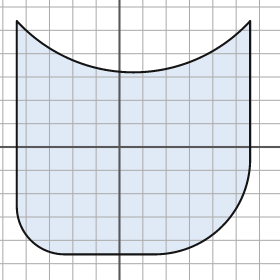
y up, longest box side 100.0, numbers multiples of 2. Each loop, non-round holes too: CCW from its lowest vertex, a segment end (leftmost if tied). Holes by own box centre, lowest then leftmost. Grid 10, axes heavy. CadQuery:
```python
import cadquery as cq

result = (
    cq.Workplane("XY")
    .moveTo(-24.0, -46.0)
    .lineTo(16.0, -46.0)
    .threePointArc((44.0, -34.0), (56.0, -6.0))
    .lineTo(56.0, 54.0)
    .threePointArc((6.0, 32.0), (-44.0, 54.0))
    .lineTo(-44.0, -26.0)
    .threePointArc((-38.0, -40.0), (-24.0, -46.0))
    .close()
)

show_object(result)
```